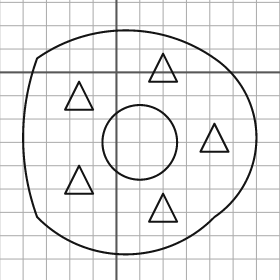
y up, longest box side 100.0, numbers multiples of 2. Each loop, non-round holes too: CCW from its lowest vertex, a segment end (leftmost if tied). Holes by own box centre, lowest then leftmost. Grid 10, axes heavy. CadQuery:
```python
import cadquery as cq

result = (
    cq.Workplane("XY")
    .moveTo(-34.0, -62.0)
    .threePointArc((4.0, -78.0), (42.0, -62.0))
    .threePointArc((60.0, -28.0), (42.0, 6.0))
    .threePointArc((4.0, 18.0), (-34.0, 6.0))
    .threePointArc((-40.0, -28.0), (-34.0, -62.0))
    .close()
    .moveTo(14.0, -64.0)
    .lineTo(26.0, -64.0)
    .lineTo(20.0, -52.0)
    .close()
    .moveTo(-22.0, -52.0)
    .lineTo(-10.0, -52.0)
    .lineTo(-16.0, -40.0)
    .close()
    .moveTo(10.0, -30.0)
    .circle(16.0)
    .moveTo(36.0, -34.0)
    .lineTo(48.0, -34.0)
    .lineTo(42.0, -22.0)
    .close()
    .moveTo(-22.0, -16.0)
    .lineTo(-10.0, -16.0)
    .lineTo(-16.0, -4.0)
    .close()
    .moveTo(14.0, -4.0)
    .lineTo(26.0, -4.0)
    .lineTo(20.0, 8.0)
    .close()
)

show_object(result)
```